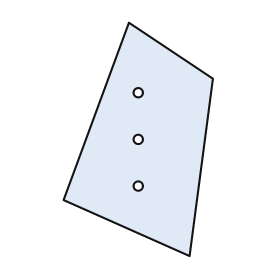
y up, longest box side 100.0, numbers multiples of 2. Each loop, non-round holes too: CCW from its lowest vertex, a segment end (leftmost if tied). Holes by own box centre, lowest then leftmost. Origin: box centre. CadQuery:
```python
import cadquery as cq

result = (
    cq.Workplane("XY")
    .moveTo(22.0, -50.0)
    .lineTo(32.0, 26.0)
    .lineTo(-4.0, 50.0)
    .lineTo(-32.0, -26.0)
    .close()
    .moveTo(0.0, -20.0)
    .circle(2.0)
    .moveTo(0.0, 0.0)
    .circle(2.0)
    .moveTo(0.0, 20.0)
    .circle(2.0)
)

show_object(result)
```